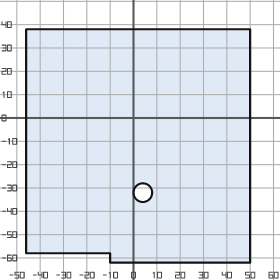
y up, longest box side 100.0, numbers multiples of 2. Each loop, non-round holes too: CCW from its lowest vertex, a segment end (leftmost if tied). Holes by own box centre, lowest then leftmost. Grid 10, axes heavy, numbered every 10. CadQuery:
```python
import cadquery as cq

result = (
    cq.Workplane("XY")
    .moveTo(-10.0, -62.0)
    .lineTo(50.0, -62.0)
    .lineTo(50.0, 38.0)
    .lineTo(-46.0, 38.0)
    .lineTo(-46.0, -58.0)
    .lineTo(-10.0, -58.0)
    .close()
    .moveTo(4.0, -32.0)
    .circle(4.0)
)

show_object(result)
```